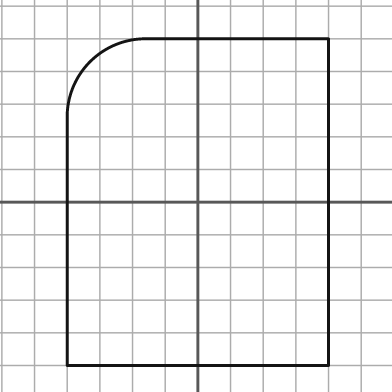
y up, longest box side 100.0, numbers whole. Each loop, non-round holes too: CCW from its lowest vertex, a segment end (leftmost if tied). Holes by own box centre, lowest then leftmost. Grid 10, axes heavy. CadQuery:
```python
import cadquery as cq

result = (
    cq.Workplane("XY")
    .moveTo(-40.0, -50.0)
    .lineTo(40.0, -50.0)
    .lineTo(40.0, 50.0)
    .lineTo(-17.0, 50.0)
    .threePointArc((-33.0, 43.0), (-40.0, 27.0))
    .close()
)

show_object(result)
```